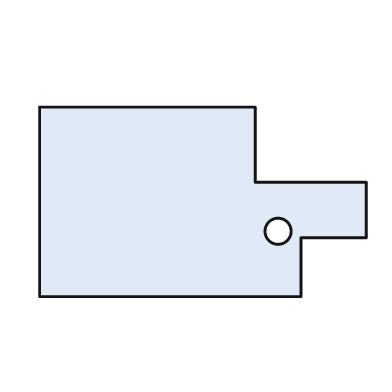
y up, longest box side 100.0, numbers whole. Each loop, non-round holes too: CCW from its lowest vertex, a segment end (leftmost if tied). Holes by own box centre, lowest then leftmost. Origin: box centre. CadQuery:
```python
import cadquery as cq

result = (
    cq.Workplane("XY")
    .moveTo(-50.0, -29.0)
    .lineTo(30.0, -29.0)
    .lineTo(30.0, -11.0)
    .lineTo(50.0, -11.0)
    .lineTo(50.0, 6.0)
    .lineTo(16.0, 6.0)
    .lineTo(16.0, 29.0)
    .lineTo(-50.0, 29.0)
    .close()
    .moveTo(23.0, -9.0)
    .circle(4.0)
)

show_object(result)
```